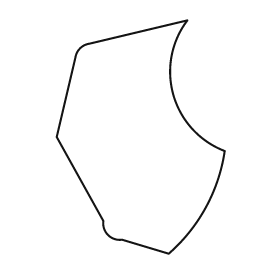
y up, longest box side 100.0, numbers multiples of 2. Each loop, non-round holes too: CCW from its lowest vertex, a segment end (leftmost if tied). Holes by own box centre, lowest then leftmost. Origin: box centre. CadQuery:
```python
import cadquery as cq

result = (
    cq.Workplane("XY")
    .moveTo(12.0, -50.0)
    .threePointArc((28.0, -30.0), (36.0, -6.0))
    .threePointArc((14.0, 18.0), (20.0, 50.0))
    .lineTo(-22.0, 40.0)
    .threePointArc((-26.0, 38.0), (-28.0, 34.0))
    .lineTo(-36.0, 0.0)
    .lineTo(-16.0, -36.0)
    .threePointArc((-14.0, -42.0), (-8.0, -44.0))
    .close()
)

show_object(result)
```